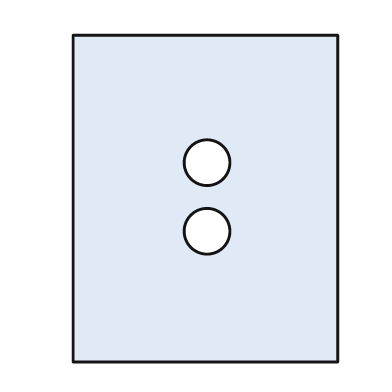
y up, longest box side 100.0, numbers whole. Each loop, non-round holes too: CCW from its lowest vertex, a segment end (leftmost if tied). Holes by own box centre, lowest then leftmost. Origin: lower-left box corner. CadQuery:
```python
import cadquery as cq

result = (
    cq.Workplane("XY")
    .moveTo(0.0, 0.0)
    .lineTo(81.0, 0.0)
    .lineTo(81.0, 100.0)
    .lineTo(0.0, 100.0)
    .close()
    .moveTo(41.0, 40.0)
    .circle(7.0)
    .moveTo(41.0, 61.0)
    .circle(7.0)
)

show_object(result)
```